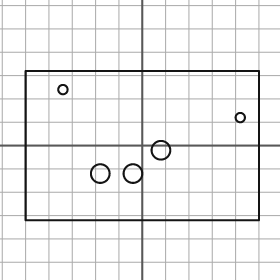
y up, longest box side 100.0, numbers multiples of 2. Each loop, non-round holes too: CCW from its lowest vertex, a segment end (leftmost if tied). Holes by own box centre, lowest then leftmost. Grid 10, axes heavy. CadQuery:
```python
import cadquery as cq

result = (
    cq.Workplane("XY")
    .moveTo(-50.0, -32.0)
    .lineTo(50.0, -32.0)
    .lineTo(50.0, 32.0)
    .lineTo(-50.0, 32.0)
    .close()
    .moveTo(-18.0, -12.0)
    .circle(4.0)
    .moveTo(-4.0, -12.0)
    .circle(4.0)
    .moveTo(8.0, -2.0)
    .circle(4.0)
    .moveTo(42.0, 12.0)
    .circle(2.0)
    .moveTo(-34.0, 24.0)
    .circle(2.0)
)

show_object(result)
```